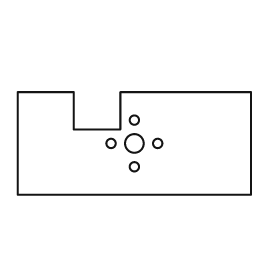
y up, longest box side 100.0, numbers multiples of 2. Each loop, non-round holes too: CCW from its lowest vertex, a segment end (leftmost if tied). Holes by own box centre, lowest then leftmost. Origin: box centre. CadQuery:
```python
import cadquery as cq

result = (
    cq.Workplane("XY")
    .moveTo(-50.0, -22.0)
    .lineTo(50.0, -22.0)
    .lineTo(50.0, 22.0)
    .lineTo(-6.0, 22.0)
    .lineTo(-6.0, 6.0)
    .lineTo(-26.0, 6.0)
    .lineTo(-26.0, 22.0)
    .lineTo(-50.0, 22.0)
    .close()
    .moveTo(0.0, -10.0)
    .circle(2.0)
    .moveTo(-10.0, 0.0)
    .circle(2.0)
    .moveTo(0.0, 0.0)
    .circle(4.0)
    .moveTo(10.0, 0.0)
    .circle(2.0)
    .moveTo(0.0, 10.0)
    .circle(2.0)
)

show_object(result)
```